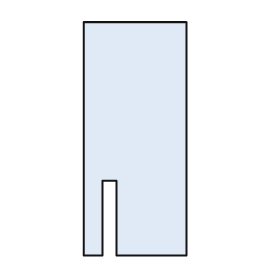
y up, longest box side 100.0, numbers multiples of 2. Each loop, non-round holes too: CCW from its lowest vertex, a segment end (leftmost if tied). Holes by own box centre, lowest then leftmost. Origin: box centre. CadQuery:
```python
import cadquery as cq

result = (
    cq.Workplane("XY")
    .moveTo(-22.0, -50.0)
    .lineTo(-14.0, -50.0)
    .lineTo(-14.0, -18.0)
    .lineTo(-8.0, -18.0)
    .lineTo(-8.0, -50.0)
    .lineTo(22.0, -50.0)
    .lineTo(22.0, 50.0)
    .lineTo(-22.0, 50.0)
    .close()
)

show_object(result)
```